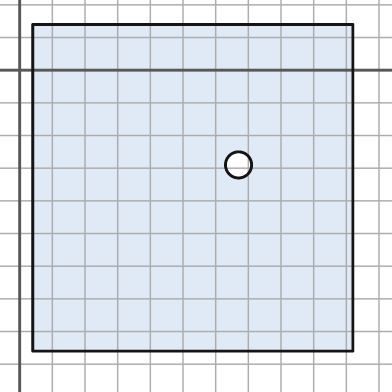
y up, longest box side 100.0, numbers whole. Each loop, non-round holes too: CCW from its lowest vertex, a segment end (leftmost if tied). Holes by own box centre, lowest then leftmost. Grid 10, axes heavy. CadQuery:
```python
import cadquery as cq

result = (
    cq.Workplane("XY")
    .moveTo(4.0, -86.0)
    .lineTo(102.0, -86.0)
    .lineTo(102.0, 14.0)
    .lineTo(4.0, 14.0)
    .close()
    .moveTo(67.0, -29.0)
    .circle(4.0)
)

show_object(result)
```